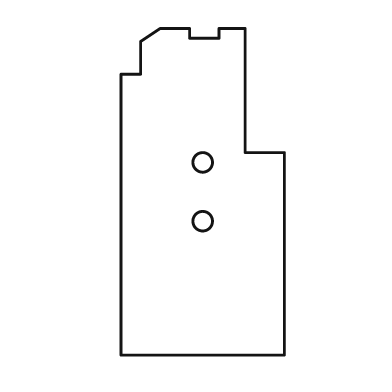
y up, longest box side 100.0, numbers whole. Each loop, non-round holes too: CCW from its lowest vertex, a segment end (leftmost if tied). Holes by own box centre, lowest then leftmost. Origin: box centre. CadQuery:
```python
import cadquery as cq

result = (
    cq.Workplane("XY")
    .moveTo(-25.0, -50.0)
    .lineTo(25.0, -50.0)
    .lineTo(25.0, 12.0)
    .lineTo(13.0, 12.0)
    .lineTo(13.0, 50.0)
    .lineTo(5.0, 50.0)
    .lineTo(5.0, 47.0)
    .lineTo(-4.0, 47.0)
    .lineTo(-4.0, 50.0)
    .lineTo(-13.0, 50.0)
    .lineTo(-19.0, 46.0)
    .lineTo(-19.0, 36.0)
    .lineTo(-25.0, 36.0)
    .close()
    .moveTo(0.0, -9.0)
    .circle(3.0)
    .moveTo(0.0, 9.0)
    .circle(3.0)
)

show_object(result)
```